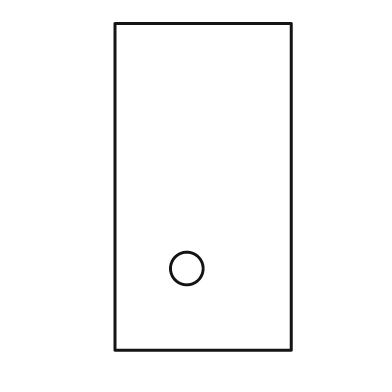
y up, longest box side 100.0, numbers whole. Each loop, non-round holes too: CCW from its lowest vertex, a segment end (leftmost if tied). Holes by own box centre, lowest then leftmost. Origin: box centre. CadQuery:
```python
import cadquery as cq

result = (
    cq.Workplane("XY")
    .moveTo(-27.0, -50.0)
    .lineTo(27.0, -50.0)
    .lineTo(27.0, 50.0)
    .lineTo(-27.0, 50.0)
    .close()
    .moveTo(-5.0, -25.0)
    .circle(5.0)
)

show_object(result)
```